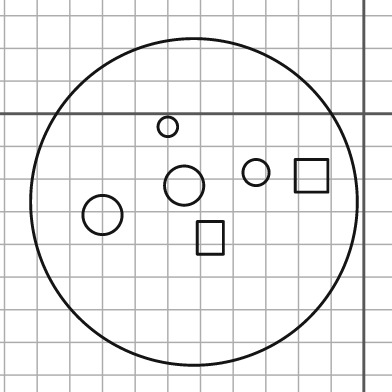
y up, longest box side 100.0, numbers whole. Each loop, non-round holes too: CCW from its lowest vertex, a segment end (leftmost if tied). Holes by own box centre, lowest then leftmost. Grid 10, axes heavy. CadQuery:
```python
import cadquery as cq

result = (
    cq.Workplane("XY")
    .moveTo(-52.0, -27.0)
    .circle(50.0)
    .moveTo(-51.0, -43.0)
    .lineTo(-43.0, -43.0)
    .lineTo(-43.0, -33.0)
    .lineTo(-51.0, -33.0)
    .close()
    .moveTo(-80.0, -31.0)
    .circle(6.0)
    .moveTo(-55.0, -22.0)
    .circle(6.0)
    .moveTo(-21.0, -24.0)
    .lineTo(-11.0, -24.0)
    .lineTo(-11.0, -14.0)
    .lineTo(-21.0, -14.0)
    .close()
    .moveTo(-33.0, -18.0)
    .circle(4.0)
    .moveTo(-60.0, -4.0)
    .circle(3.0)
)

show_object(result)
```